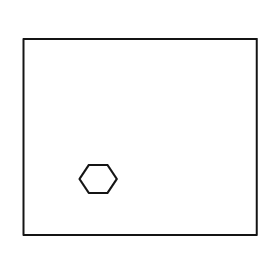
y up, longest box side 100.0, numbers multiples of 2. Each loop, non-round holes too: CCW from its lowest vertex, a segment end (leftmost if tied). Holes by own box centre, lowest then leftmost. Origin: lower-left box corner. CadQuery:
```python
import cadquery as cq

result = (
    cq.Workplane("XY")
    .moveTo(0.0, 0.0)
    .lineTo(100.0, 0.0)
    .lineTo(100.0, 84.0)
    .lineTo(0.0, 84.0)
    .close()
    .moveTo(28.0, 18.0)
    .lineTo(36.0, 18.0)
    .lineTo(40.0, 24.0)
    .lineTo(36.0, 30.0)
    .lineTo(28.0, 30.0)
    .lineTo(24.0, 24.0)
    .close()
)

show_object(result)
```